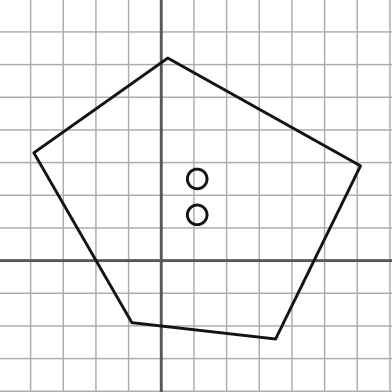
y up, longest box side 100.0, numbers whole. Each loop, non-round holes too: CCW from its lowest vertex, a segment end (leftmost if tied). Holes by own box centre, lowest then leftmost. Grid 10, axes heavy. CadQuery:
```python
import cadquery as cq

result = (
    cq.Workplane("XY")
    .moveTo(35.0, -24.0)
    .lineTo(61.0, 29.0)
    .lineTo(2.0, 62.0)
    .lineTo(-39.0, 33.0)
    .lineTo(-9.0, -19.0)
    .close()
    .moveTo(11.0, 14.0)
    .circle(3.0)
    .moveTo(11.0, 25.0)
    .circle(3.0)
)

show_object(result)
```